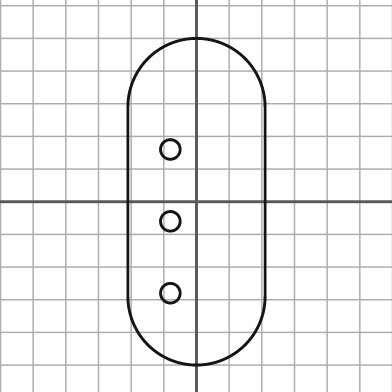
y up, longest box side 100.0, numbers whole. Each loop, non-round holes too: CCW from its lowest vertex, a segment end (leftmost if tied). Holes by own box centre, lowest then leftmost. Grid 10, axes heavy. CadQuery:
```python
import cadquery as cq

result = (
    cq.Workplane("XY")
    .moveTo(-21.0, -29.0)
    .threePointArc((0.0, -50.0), (21.0, -29.0))
    .lineTo(21.0, 29.0)
    .threePointArc((0.0, 50.0), (-21.0, 29.0))
    .close()
    .moveTo(-8.0, -28.0)
    .circle(3.0)
    .moveTo(-8.0, -6.0)
    .circle(3.0)
    .moveTo(-8.0, 16.0)
    .circle(3.0)
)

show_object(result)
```